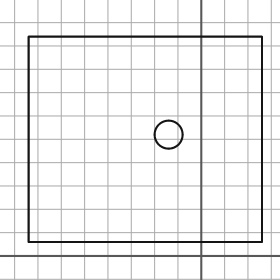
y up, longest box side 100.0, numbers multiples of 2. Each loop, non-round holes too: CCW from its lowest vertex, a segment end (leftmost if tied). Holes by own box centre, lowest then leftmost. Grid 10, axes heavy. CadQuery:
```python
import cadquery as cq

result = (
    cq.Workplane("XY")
    .moveTo(-74.0, 6.0)
    .lineTo(26.0, 6.0)
    .lineTo(26.0, 94.0)
    .lineTo(-74.0, 94.0)
    .close()
    .moveTo(-14.0, 52.0)
    .circle(6.0)
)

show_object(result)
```